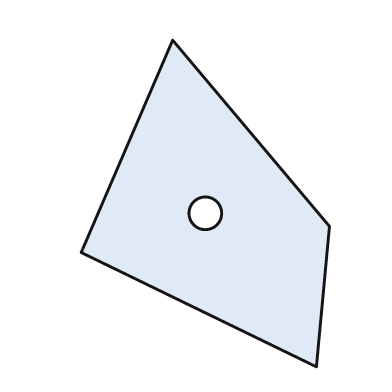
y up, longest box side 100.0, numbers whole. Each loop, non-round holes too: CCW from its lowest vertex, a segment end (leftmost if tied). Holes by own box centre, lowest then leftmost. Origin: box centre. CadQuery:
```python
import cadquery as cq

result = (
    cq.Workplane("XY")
    .moveTo(34.0, -50.0)
    .lineTo(38.0, -7.0)
    .lineTo(-10.0, 50.0)
    .lineTo(-38.0, -15.0)
    .close()
    .moveTo(0.0, -3.0)
    .circle(5.0)
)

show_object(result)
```